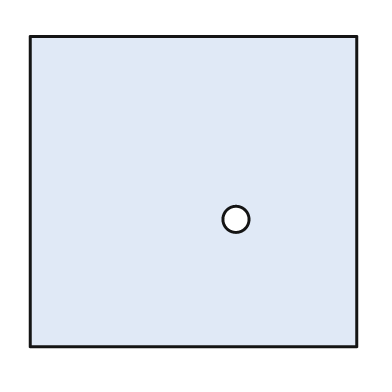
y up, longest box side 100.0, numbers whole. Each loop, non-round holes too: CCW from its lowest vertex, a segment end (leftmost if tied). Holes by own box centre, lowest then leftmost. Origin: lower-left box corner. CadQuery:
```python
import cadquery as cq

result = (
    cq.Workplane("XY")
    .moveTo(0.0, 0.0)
    .lineTo(100.0, 0.0)
    .lineTo(100.0, 95.0)
    .lineTo(0.0, 95.0)
    .close()
    .moveTo(63.0, 39.0)
    .circle(4.0)
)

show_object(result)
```